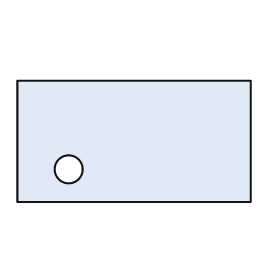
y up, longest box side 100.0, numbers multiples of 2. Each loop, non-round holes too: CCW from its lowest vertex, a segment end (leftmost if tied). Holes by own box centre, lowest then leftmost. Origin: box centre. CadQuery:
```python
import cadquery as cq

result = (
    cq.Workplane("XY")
    .moveTo(-50.0, -26.0)
    .lineTo(50.0, -26.0)
    .lineTo(50.0, 26.0)
    .lineTo(-50.0, 26.0)
    .close()
    .moveTo(-28.0, -12.0)
    .circle(6.0)
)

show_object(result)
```